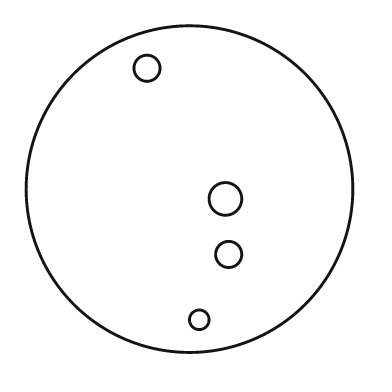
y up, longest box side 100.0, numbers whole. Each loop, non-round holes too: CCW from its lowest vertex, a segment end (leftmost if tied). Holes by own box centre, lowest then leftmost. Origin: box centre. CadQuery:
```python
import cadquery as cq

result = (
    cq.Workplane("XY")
    .moveTo(0.0, 0.0)
    .circle(50.0)
    .moveTo(3.0, -40.0)
    .circle(3.0)
    .moveTo(12.0, -20.0)
    .circle(4.0)
    .moveTo(11.0, -3.0)
    .circle(5.0)
    .moveTo(-13.0, 37.0)
    .circle(4.0)
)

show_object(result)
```